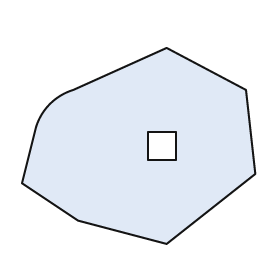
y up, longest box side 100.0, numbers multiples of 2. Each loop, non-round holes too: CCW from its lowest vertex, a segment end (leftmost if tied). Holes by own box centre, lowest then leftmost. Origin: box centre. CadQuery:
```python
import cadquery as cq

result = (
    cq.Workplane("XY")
    .moveTo(12.0, -42.0)
    .lineTo(50.0, -12.0)
    .lineTo(46.0, 24.0)
    .lineTo(12.0, 42.0)
    .lineTo(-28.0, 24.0)
    .threePointArc((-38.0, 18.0), (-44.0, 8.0))
    .lineTo(-50.0, -16.0)
    .lineTo(-26.0, -32.0)
    .close()
    .moveTo(4.0, -6.0)
    .lineTo(16.0, -6.0)
    .lineTo(16.0, 6.0)
    .lineTo(4.0, 6.0)
    .close()
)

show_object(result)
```